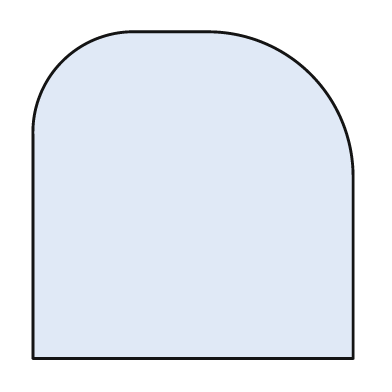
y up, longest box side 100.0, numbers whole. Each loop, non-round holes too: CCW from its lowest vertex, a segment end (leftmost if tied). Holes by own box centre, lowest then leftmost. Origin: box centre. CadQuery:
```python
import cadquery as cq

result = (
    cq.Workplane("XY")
    .moveTo(-49.0, -50.0)
    .lineTo(49.0, -50.0)
    .lineTo(49.0, 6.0)
    .threePointArc((36.0, 37.0), (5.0, 50.0))
    .lineTo(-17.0, 50.0)
    .threePointArc((-40.0, 41.0), (-49.0, 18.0))
    .close()
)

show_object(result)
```